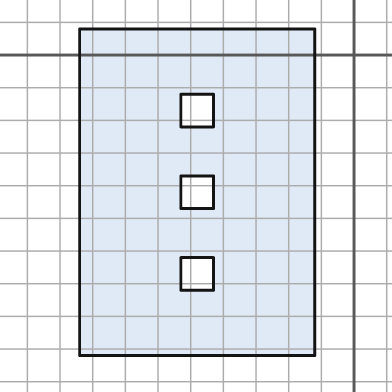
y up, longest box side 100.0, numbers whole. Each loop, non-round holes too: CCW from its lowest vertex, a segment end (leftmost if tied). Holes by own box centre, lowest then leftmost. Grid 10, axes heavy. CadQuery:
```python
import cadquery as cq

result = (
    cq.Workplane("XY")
    .moveTo(-84.0, -92.0)
    .lineTo(-12.0, -92.0)
    .lineTo(-12.0, 8.0)
    .lineTo(-84.0, 8.0)
    .close()
    .moveTo(-53.0, -72.0)
    .lineTo(-43.0, -72.0)
    .lineTo(-43.0, -62.0)
    .lineTo(-53.0, -62.0)
    .close()
    .moveTo(-53.0, -47.0)
    .lineTo(-43.0, -47.0)
    .lineTo(-43.0, -37.0)
    .lineTo(-53.0, -37.0)
    .close()
    .moveTo(-53.0, -22.0)
    .lineTo(-43.0, -22.0)
    .lineTo(-43.0, -12.0)
    .lineTo(-53.0, -12.0)
    .close()
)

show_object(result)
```